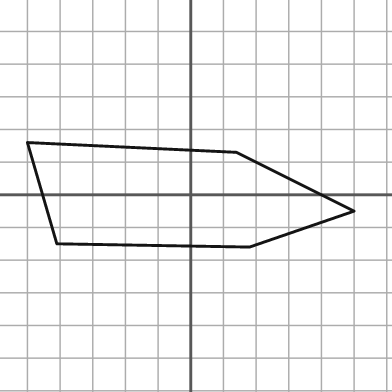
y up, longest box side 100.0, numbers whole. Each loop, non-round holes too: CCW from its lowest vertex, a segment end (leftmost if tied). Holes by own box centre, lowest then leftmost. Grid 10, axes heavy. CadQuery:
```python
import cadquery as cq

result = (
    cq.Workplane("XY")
    .moveTo(18.0, -16.0)
    .lineTo(50.0, -5.0)
    .lineTo(14.0, 13.0)
    .lineTo(-50.0, 16.0)
    .lineTo(-41.0, -15.0)
    .close()
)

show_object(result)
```